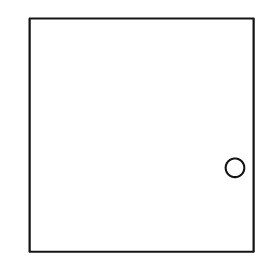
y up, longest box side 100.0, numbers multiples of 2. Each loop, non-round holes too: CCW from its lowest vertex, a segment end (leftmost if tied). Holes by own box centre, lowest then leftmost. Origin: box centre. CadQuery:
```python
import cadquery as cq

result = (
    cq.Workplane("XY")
    .moveTo(-48.0, -50.0)
    .lineTo(48.0, -50.0)
    .lineTo(48.0, 50.0)
    .lineTo(-48.0, 50.0)
    .close()
    .moveTo(40.0, -14.0)
    .circle(4.0)
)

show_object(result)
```